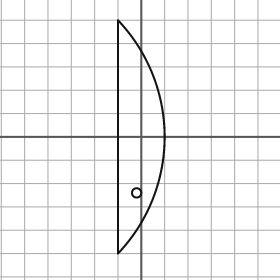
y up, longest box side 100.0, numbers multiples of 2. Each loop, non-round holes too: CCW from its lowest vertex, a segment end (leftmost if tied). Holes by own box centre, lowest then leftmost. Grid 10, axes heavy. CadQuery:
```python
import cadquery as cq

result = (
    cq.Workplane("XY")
    .moveTo(-10.0, -50.0)
    .threePointArc((10.0, 0.0), (-10.0, 50.0))
    .close()
    .moveTo(-2.0, -24.0)
    .circle(2.0)
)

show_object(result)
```